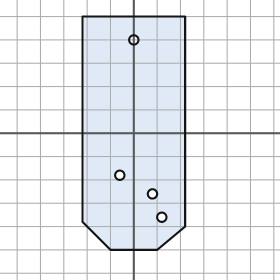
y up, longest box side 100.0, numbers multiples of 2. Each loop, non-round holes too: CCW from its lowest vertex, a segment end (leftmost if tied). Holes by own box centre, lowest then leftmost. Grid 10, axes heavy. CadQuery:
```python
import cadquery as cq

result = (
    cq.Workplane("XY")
    .moveTo(-10.0, -50.0)
    .lineTo(10.0, -50.0)
    .lineTo(22.0, -40.0)
    .lineTo(22.0, 50.0)
    .lineTo(-22.0, 50.0)
    .lineTo(-22.0, -38.0)
    .close()
    .moveTo(12.0, -36.0)
    .circle(2.0)
    .moveTo(8.0, -26.0)
    .circle(2.0)
    .moveTo(-6.0, -18.0)
    .circle(2.0)
    .moveTo(0.0, 40.0)
    .circle(2.0)
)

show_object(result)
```